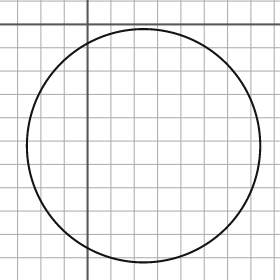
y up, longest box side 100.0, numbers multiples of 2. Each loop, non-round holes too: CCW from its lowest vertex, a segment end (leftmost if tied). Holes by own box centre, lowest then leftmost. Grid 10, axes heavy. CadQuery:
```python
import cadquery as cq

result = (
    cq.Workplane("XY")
    .moveTo(24.0, -52.0)
    .circle(50.0)
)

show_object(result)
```